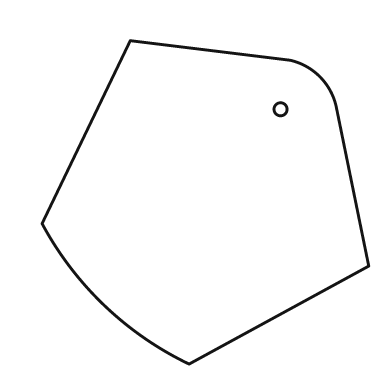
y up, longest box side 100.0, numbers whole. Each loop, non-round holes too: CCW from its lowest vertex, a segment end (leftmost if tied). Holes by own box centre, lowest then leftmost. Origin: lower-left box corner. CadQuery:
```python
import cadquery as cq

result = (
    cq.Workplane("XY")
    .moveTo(45.0, 0.0)
    .lineTo(100.0, 30.0)
    .lineTo(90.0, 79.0)
    .threePointArc((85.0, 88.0), (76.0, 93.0))
    .lineTo(27.0, 99.0)
    .lineTo(0.0, 43.0)
    .threePointArc((19.0, 18.0), (45.0, 0.0))
    .close()
    .moveTo(73.0, 78.0)
    .circle(2.0)
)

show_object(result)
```